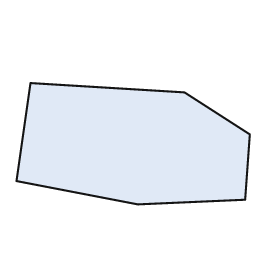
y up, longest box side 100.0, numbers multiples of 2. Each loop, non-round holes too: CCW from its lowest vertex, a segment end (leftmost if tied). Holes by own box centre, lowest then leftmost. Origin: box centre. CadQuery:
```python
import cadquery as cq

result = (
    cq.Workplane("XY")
    .moveTo(2.0, -26.0)
    .lineTo(48.0, -24.0)
    .lineTo(50.0, 4.0)
    .lineTo(22.0, 22.0)
    .lineTo(-44.0, 26.0)
    .lineTo(-50.0, -16.0)
    .close()
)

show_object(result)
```